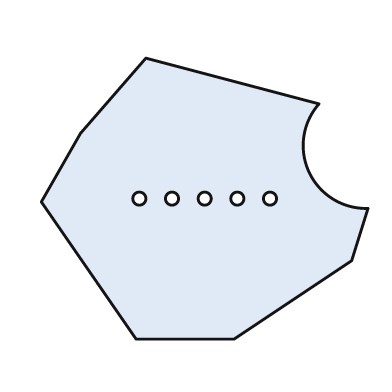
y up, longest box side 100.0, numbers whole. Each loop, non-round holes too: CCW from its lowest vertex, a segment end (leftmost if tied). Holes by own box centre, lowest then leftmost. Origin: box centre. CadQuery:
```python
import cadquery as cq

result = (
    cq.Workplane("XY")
    .moveTo(-21.0, -43.0)
    .lineTo(9.0, -43.0)
    .lineTo(45.0, -19.0)
    .lineTo(50.0, -3.0)
    .threePointArc((32.0, 8.0), (35.0, 29.0))
    .lineTo(-18.0, 43.0)
    .lineTo(-38.0, 20.0)
    .lineTo(-50.0, -1.0)
    .close()
    .moveTo(-20.0, 0.0)
    .circle(2.0)
    .moveTo(-10.0, 0.0)
    .circle(2.0)
    .moveTo(0.0, 0.0)
    .circle(2.0)
    .moveTo(10.0, 0.0)
    .circle(2.0)
    .moveTo(20.0, 0.0)
    .circle(2.0)
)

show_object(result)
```